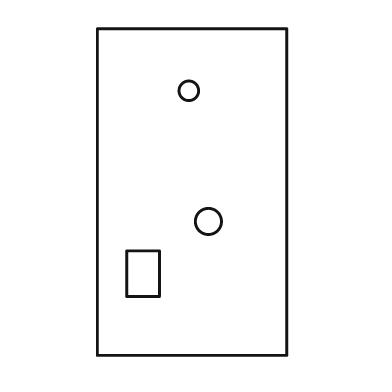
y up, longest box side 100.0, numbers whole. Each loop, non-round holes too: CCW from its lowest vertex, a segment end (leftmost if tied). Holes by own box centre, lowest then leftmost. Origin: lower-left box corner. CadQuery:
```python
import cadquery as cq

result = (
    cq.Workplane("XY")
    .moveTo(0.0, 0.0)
    .lineTo(58.0, 0.0)
    .lineTo(58.0, 100.0)
    .lineTo(0.0, 100.0)
    .close()
    .moveTo(9.0, 18.0)
    .lineTo(19.0, 18.0)
    .lineTo(19.0, 32.0)
    .lineTo(9.0, 32.0)
    .close()
    .moveTo(34.0, 41.0)
    .circle(4.0)
    .moveTo(28.0, 81.0)
    .circle(3.0)
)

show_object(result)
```